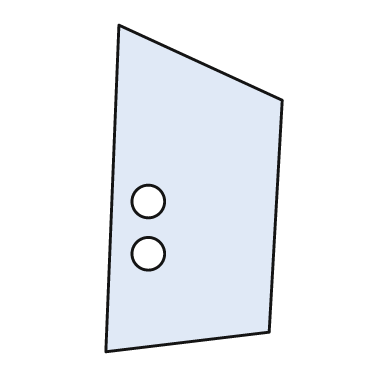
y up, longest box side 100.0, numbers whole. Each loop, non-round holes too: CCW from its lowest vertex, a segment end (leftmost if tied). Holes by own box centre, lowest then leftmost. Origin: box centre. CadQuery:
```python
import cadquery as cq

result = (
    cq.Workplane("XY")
    .moveTo(-27.0, -50.0)
    .lineTo(23.0, -44.0)
    .lineTo(27.0, 27.0)
    .lineTo(-23.0, 50.0)
    .close()
    .moveTo(-14.0, -20.0)
    .circle(5.0)
    .moveTo(-14.0, -4.0)
    .circle(5.0)
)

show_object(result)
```